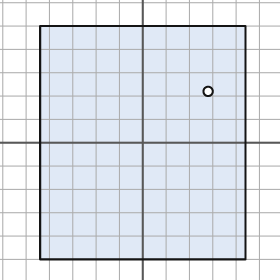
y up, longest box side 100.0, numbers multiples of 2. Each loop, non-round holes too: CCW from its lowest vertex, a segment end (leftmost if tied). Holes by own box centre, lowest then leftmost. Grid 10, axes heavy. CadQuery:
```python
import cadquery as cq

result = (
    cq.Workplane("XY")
    .moveTo(-44.0, -50.0)
    .lineTo(44.0, -50.0)
    .lineTo(44.0, 50.0)
    .lineTo(-44.0, 50.0)
    .close()
    .moveTo(28.0, 22.0)
    .circle(2.0)
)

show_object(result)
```